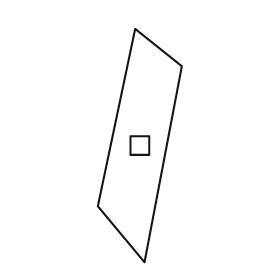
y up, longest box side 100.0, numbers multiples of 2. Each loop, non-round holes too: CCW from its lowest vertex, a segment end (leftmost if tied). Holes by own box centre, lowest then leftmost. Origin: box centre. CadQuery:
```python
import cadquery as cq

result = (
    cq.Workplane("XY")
    .moveTo(2.0, -50.0)
    .lineTo(18.0, 34.0)
    .lineTo(-2.0, 50.0)
    .lineTo(-18.0, -26.0)
    .close()
    .moveTo(-4.0, -4.0)
    .lineTo(4.0, -4.0)
    .lineTo(4.0, 4.0)
    .lineTo(-4.0, 4.0)
    .close()
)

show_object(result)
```